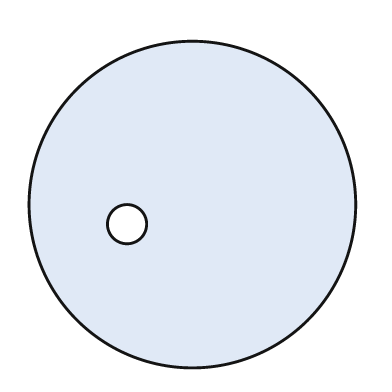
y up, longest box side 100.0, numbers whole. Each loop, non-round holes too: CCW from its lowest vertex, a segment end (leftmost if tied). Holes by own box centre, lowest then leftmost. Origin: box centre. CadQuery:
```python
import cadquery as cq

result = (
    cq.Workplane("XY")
    .moveTo(0.0, 0.0)
    .circle(50.0)
    .moveTo(-20.0, -6.0)
    .circle(6.0)
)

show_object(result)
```